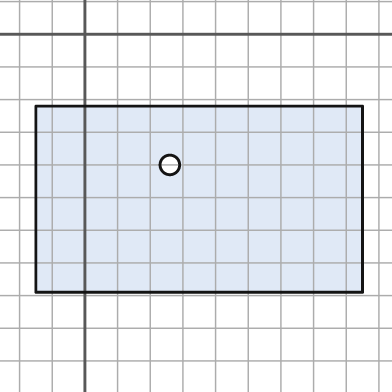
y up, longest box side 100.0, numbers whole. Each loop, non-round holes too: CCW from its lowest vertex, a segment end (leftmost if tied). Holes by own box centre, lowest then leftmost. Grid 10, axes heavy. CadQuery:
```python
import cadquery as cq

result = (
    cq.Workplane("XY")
    .moveTo(-15.0, -79.0)
    .lineTo(85.0, -79.0)
    .lineTo(85.0, -22.0)
    .lineTo(-15.0, -22.0)
    .close()
    .moveTo(26.0, -40.0)
    .circle(3.0)
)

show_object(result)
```